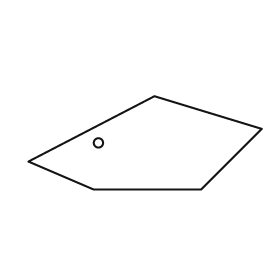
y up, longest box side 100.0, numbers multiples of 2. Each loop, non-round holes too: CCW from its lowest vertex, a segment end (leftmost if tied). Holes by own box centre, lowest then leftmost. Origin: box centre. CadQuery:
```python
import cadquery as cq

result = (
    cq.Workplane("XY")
    .moveTo(-22.0, -20.0)
    .lineTo(24.0, -20.0)
    .lineTo(50.0, 6.0)
    .lineTo(4.0, 20.0)
    .lineTo(-50.0, -8.0)
    .close()
    .moveTo(-20.0, 0.0)
    .circle(2.0)
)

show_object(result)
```